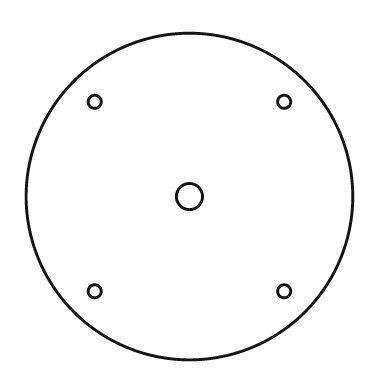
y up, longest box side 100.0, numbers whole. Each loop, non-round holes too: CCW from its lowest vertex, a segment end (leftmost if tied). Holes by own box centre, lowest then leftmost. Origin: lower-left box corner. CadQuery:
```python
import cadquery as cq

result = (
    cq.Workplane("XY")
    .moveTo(50.0, 50.0)
    .circle(50.0)
    .moveTo(21.0, 21.0)
    .circle(2.0)
    .moveTo(79.0, 21.0)
    .circle(2.0)
    .moveTo(50.0, 50.0)
    .circle(4.0)
    .moveTo(21.0, 79.0)
    .circle(2.0)
    .moveTo(79.0, 79.0)
    .circle(2.0)
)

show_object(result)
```